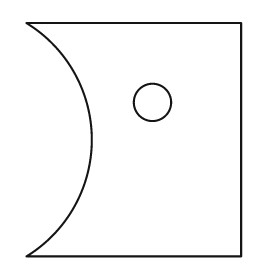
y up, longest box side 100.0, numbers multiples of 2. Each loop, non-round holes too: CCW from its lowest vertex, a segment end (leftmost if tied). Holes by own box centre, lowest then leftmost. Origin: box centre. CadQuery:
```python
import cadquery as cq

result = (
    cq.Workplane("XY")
    .moveTo(-46.0, -50.0)
    .lineTo(46.0, -50.0)
    .lineTo(46.0, 50.0)
    .lineTo(-46.0, 50.0)
    .threePointArc((-18.0, 0.0), (-46.0, -50.0))
    .close()
    .moveTo(8.0, 16.0)
    .circle(8.0)
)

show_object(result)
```